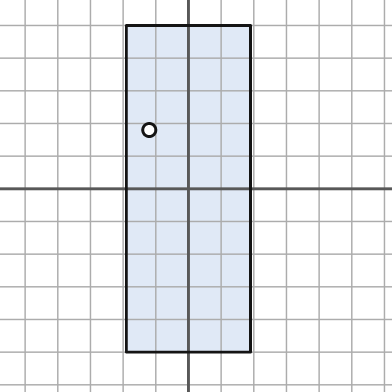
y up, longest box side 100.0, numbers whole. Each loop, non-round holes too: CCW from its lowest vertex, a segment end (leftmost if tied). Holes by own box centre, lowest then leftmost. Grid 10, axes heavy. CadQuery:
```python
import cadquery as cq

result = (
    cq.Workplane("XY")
    .moveTo(-19.0, -50.0)
    .lineTo(19.0, -50.0)
    .lineTo(19.0, 50.0)
    .lineTo(-19.0, 50.0)
    .close()
    .moveTo(-12.0, 18.0)
    .circle(2.0)
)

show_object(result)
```